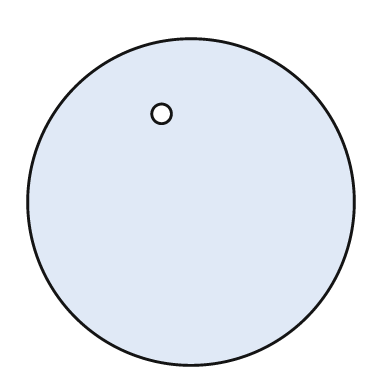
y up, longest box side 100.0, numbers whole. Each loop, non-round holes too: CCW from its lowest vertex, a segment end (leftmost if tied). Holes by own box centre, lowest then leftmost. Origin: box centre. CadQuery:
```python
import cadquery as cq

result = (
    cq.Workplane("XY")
    .moveTo(0.0, 0.0)
    .circle(50.0)
    .moveTo(-9.0, 27.0)
    .circle(3.0)
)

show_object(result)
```